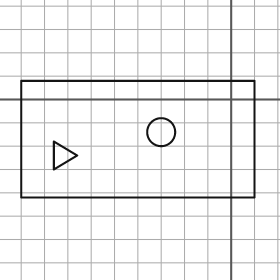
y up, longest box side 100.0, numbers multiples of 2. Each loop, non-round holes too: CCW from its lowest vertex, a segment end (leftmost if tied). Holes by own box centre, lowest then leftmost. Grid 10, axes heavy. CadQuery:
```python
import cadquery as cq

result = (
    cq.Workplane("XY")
    .moveTo(-90.0, -42.0)
    .lineTo(10.0, -42.0)
    .lineTo(10.0, 8.0)
    .lineTo(-90.0, 8.0)
    .close()
    .moveTo(-76.0, -30.0)
    .lineTo(-66.0, -24.0)
    .lineTo(-76.0, -18.0)
    .close()
    .moveTo(-30.0, -14.0)
    .circle(6.0)
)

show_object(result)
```